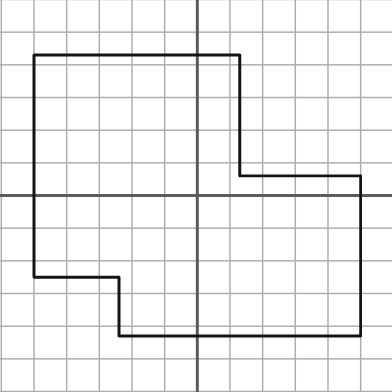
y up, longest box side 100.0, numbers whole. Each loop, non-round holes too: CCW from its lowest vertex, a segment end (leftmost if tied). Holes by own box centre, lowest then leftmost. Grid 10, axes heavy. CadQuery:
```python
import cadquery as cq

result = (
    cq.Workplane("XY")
    .moveTo(-24.0, -43.0)
    .lineTo(50.0, -43.0)
    .lineTo(50.0, 6.0)
    .lineTo(13.0, 6.0)
    .lineTo(13.0, 43.0)
    .lineTo(-50.0, 43.0)
    .lineTo(-50.0, -25.0)
    .lineTo(-24.0, -25.0)
    .close()
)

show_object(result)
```